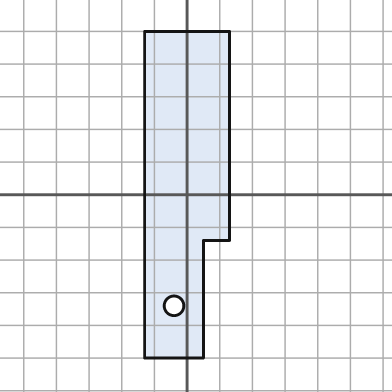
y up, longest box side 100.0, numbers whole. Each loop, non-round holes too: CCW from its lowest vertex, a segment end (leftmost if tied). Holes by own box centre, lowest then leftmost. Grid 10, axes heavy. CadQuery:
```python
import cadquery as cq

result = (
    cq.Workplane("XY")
    .moveTo(-13.0, -50.0)
    .lineTo(5.0, -50.0)
    .lineTo(5.0, -14.0)
    .lineTo(13.0, -14.0)
    .lineTo(13.0, 50.0)
    .lineTo(-13.0, 50.0)
    .close()
    .moveTo(-4.0, -34.0)
    .circle(3.0)
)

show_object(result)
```